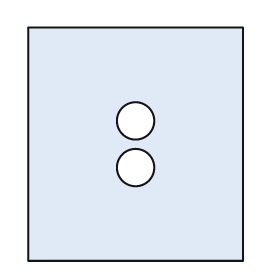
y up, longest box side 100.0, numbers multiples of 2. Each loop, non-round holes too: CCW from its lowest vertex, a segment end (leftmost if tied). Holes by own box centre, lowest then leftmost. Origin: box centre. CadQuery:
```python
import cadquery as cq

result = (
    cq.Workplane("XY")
    .moveTo(-46.0, -50.0)
    .lineTo(46.0, -50.0)
    .lineTo(46.0, 50.0)
    .lineTo(-46.0, 50.0)
    .close()
    .moveTo(0.0, -10.0)
    .circle(8.0)
    .moveTo(0.0, 10.0)
    .circle(8.0)
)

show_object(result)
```